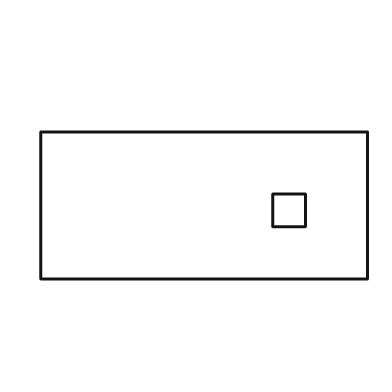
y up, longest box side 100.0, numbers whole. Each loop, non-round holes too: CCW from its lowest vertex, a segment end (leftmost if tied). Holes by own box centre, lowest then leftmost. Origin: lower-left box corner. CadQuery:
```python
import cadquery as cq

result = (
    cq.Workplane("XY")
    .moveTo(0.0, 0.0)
    .lineTo(100.0, 0.0)
    .lineTo(100.0, 45.0)
    .lineTo(0.0, 45.0)
    .close()
    .moveTo(71.0, 16.0)
    .lineTo(81.0, 16.0)
    .lineTo(81.0, 26.0)
    .lineTo(71.0, 26.0)
    .close()
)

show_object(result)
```